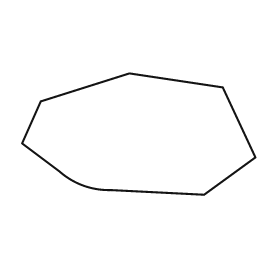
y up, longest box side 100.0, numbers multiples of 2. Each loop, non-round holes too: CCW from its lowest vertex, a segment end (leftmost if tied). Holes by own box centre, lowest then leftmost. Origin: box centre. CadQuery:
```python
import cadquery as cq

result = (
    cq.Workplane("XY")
    .moveTo(28.0, -26.0)
    .lineTo(50.0, -10.0)
    .lineTo(36.0, 20.0)
    .lineTo(-4.0, 26.0)
    .lineTo(-42.0, 14.0)
    .lineTo(-50.0, -4.0)
    .lineTo(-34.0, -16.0)
    .threePointArc((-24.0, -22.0), (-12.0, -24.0))
    .close()
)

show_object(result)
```